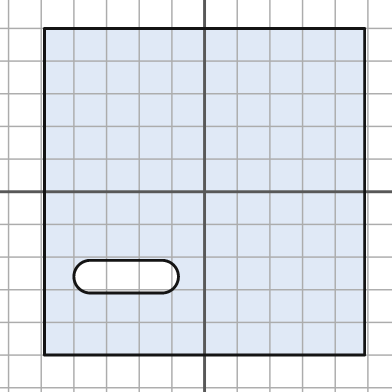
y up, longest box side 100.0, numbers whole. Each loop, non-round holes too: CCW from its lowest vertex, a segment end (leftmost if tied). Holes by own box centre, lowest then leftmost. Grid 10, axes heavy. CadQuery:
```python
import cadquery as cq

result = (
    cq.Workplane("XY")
    .moveTo(-49.0, -50.0)
    .lineTo(49.0, -50.0)
    .lineTo(49.0, 50.0)
    .lineTo(-49.0, 50.0)
    .close()
    .moveTo(-35.0, -31.0)
    .lineTo(-13.0, -31.0)
    .threePointArc((-8.0, -26.0), (-13.0, -21.0))
    .lineTo(-35.0, -21.0)
    .threePointArc((-40.0, -26.0), (-35.0, -31.0))
    .close()
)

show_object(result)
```